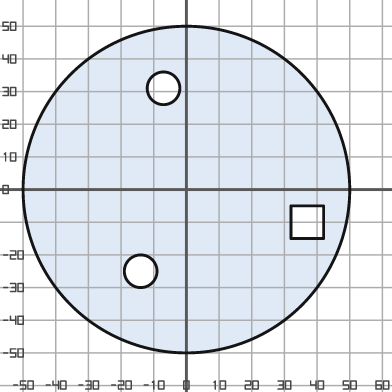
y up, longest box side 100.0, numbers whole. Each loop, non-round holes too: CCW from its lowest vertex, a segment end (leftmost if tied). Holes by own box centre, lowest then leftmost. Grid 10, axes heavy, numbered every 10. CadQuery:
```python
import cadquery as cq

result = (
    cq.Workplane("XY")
    .moveTo(0.0, 0.0)
    .circle(50.0)
    .moveTo(-14.0, -25.0)
    .circle(5.0)
    .moveTo(32.0, -15.0)
    .lineTo(42.0, -15.0)
    .lineTo(42.0, -5.0)
    .lineTo(32.0, -5.0)
    .close()
    .moveTo(-7.0, 31.0)
    .circle(5.0)
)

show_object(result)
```